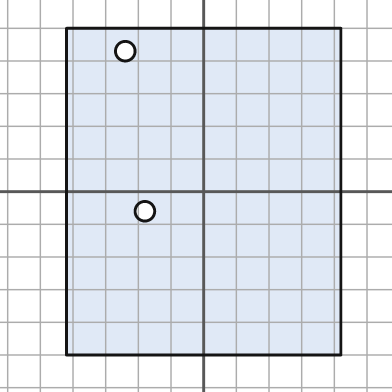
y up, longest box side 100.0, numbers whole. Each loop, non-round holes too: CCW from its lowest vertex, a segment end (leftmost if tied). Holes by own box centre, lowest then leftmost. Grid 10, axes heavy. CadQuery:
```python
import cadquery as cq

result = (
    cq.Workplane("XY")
    .moveTo(-42.0, -50.0)
    .lineTo(42.0, -50.0)
    .lineTo(42.0, 50.0)
    .lineTo(-42.0, 50.0)
    .close()
    .moveTo(-18.0, -6.0)
    .circle(3.0)
    .moveTo(-24.0, 43.0)
    .circle(3.0)
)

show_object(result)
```